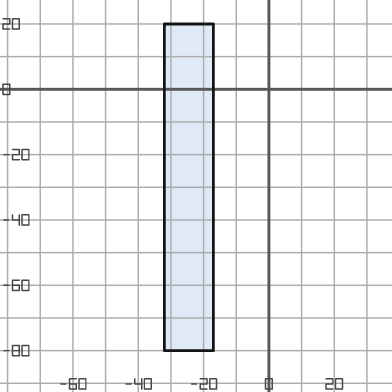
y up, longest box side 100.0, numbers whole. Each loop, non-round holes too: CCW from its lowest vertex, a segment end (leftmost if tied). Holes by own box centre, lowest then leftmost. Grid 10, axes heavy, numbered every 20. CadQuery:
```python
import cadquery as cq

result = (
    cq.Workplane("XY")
    .moveTo(-32.0, -80.0)
    .lineTo(-17.0, -80.0)
    .lineTo(-17.0, 20.0)
    .lineTo(-32.0, 20.0)
    .close()
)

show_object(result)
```